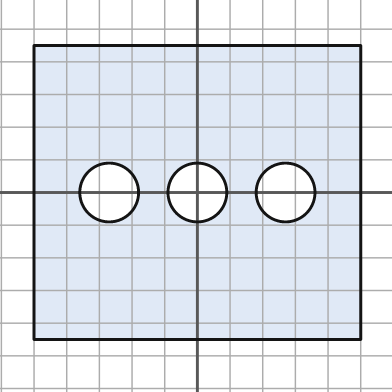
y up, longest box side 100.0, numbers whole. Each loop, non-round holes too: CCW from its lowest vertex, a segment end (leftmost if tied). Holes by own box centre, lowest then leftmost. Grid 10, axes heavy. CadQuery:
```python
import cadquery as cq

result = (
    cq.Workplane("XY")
    .moveTo(-50.0, -45.0)
    .lineTo(50.0, -45.0)
    .lineTo(50.0, 45.0)
    .lineTo(-50.0, 45.0)
    .close()
    .moveTo(-27.0, 0.0)
    .circle(9.0)
    .moveTo(0.0, 0.0)
    .circle(9.0)
    .moveTo(27.0, 0.0)
    .circle(9.0)
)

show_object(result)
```